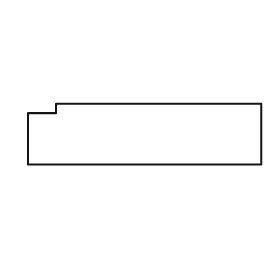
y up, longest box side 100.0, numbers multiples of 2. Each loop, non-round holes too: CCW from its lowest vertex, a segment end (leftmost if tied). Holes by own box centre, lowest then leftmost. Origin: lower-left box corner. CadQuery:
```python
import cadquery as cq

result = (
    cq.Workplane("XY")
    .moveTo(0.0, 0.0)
    .lineTo(100.0, 0.0)
    .lineTo(100.0, 26.0)
    .lineTo(12.0, 26.0)
    .lineTo(12.0, 22.0)
    .lineTo(0.0, 22.0)
    .close()
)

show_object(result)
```